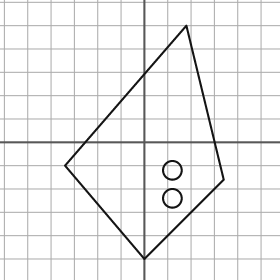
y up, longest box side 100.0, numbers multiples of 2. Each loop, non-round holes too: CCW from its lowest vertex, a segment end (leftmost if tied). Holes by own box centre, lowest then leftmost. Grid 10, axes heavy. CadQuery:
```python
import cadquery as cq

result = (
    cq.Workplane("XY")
    .moveTo(0.0, -50.0)
    .lineTo(34.0, -16.0)
    .lineTo(18.0, 50.0)
    .lineTo(-34.0, -10.0)
    .close()
    .moveTo(12.0, -24.0)
    .circle(4.0)
    .moveTo(12.0, -12.0)
    .circle(4.0)
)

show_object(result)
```